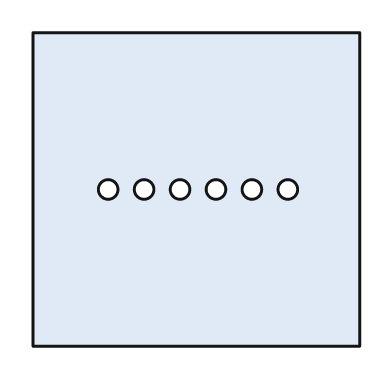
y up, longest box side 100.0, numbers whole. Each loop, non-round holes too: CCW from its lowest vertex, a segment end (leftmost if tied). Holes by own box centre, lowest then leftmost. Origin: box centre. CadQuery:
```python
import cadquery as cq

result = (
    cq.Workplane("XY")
    .moveTo(-50.0, -48.0)
    .lineTo(50.0, -48.0)
    .lineTo(50.0, 48.0)
    .lineTo(-50.0, 48.0)
    .close()
    .moveTo(-27.0, 0.0)
    .circle(3.0)
    .moveTo(-16.0, 0.0)
    .circle(3.0)
    .moveTo(-5.0, 0.0)
    .circle(3.0)
    .moveTo(6.0, 0.0)
    .circle(3.0)
    .moveTo(17.0, 0.0)
    .circle(3.0)
    .moveTo(28.0, 0.0)
    .circle(3.0)
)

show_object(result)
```